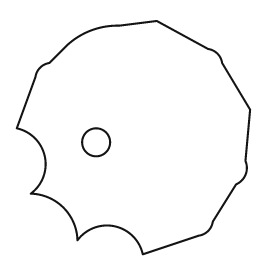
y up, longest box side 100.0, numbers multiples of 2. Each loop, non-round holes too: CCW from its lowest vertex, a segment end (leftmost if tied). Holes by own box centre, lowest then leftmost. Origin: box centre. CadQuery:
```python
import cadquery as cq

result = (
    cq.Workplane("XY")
    .moveTo(4.0, -50.0)
    .lineTo(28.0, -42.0)
    .threePointArc((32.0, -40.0), (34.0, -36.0))
    .lineTo(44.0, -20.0)
    .threePointArc((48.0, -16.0), (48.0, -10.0))
    .lineTo(50.0, 12.0)
    .lineTo(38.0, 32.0)
    .threePointArc((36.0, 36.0), (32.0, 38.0))
    .lineTo(10.0, 50.0)
    .lineTo(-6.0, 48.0)
    .threePointArc((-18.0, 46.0), (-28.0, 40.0))
    .lineTo(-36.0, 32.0)
    .threePointArc((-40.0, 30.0), (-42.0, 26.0))
    .lineTo(-50.0, 4.0)
    .threePointArc((-38.0, -8.0), (-44.0, -24.0))
    .threePointArc((-30.0, -30.0), (-24.0, -44.0))
    .threePointArc((-8.0, -38.0), (4.0, -50.0))
    .close()
    .moveTo(-16.0, -2.0)
    .circle(6.0)
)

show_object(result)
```